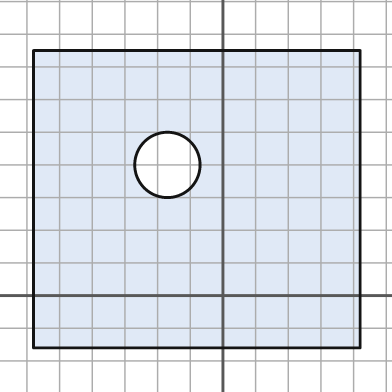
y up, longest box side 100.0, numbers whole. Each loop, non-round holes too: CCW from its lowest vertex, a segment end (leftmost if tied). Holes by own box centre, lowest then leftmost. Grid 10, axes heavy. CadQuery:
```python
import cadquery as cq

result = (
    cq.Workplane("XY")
    .moveTo(-58.0, -16.0)
    .lineTo(42.0, -16.0)
    .lineTo(42.0, 75.0)
    .lineTo(-58.0, 75.0)
    .close()
    .moveTo(-17.0, 40.0)
    .circle(10.0)
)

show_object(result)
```